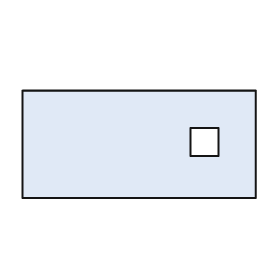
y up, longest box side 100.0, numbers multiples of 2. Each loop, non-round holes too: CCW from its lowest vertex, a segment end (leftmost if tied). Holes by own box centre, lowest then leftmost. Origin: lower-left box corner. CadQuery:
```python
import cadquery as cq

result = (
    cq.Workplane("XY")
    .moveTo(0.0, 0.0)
    .lineTo(100.0, 0.0)
    .lineTo(100.0, 46.0)
    .lineTo(0.0, 46.0)
    .close()
    .moveTo(72.0, 18.0)
    .lineTo(84.0, 18.0)
    .lineTo(84.0, 30.0)
    .lineTo(72.0, 30.0)
    .close()
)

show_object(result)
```